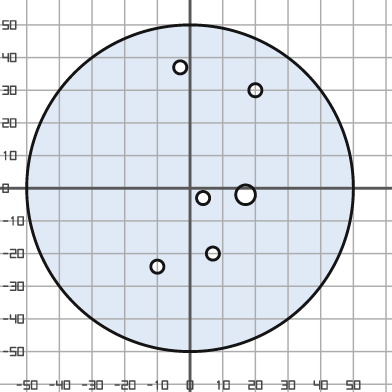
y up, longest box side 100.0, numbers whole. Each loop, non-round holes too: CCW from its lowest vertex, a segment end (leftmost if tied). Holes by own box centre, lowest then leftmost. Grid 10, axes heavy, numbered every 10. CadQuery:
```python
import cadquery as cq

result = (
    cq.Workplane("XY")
    .moveTo(0.0, 0.0)
    .circle(50.0)
    .moveTo(-10.0, -24.0)
    .circle(2.0)
    .moveTo(7.0, -20.0)
    .circle(2.0)
    .moveTo(4.0, -3.0)
    .circle(2.0)
    .moveTo(17.0, -2.0)
    .circle(3.0)
    .moveTo(20.0, 30.0)
    .circle(2.0)
    .moveTo(-3.0, 37.0)
    .circle(2.0)
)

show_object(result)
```